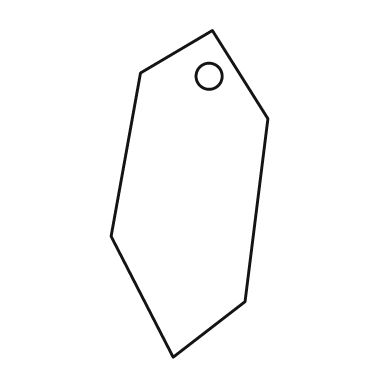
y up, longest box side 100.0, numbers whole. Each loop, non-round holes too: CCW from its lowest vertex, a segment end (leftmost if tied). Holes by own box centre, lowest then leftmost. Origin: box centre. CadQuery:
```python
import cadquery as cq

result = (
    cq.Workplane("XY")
    .moveTo(-5.0, -50.0)
    .lineTo(17.0, -33.0)
    .lineTo(24.0, 23.0)
    .lineTo(7.0, 50.0)
    .lineTo(-15.0, 37.0)
    .lineTo(-24.0, -13.0)
    .close()
    .moveTo(6.0, 36.0)
    .circle(4.0)
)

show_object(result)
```